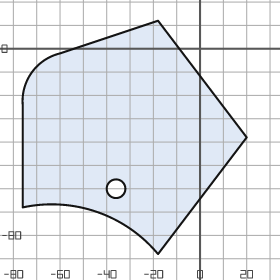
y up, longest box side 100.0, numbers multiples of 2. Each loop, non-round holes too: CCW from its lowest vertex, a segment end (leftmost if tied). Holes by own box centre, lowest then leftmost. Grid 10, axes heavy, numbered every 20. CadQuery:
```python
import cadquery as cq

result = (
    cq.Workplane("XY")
    .moveTo(-18.0, -88.0)
    .lineTo(20.0, -38.0)
    .lineTo(-18.0, 12.0)
    .lineTo(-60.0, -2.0)
    .threePointArc((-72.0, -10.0), (-76.0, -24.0))
    .lineTo(-76.0, -68.0)
    .threePointArc((-44.0, -70.0), (-18.0, -88.0))
    .close()
    .moveTo(-36.0, -60.0)
    .circle(4.0)
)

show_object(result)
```